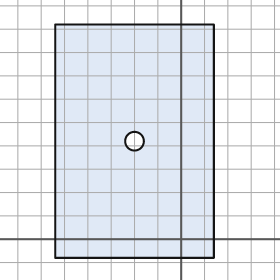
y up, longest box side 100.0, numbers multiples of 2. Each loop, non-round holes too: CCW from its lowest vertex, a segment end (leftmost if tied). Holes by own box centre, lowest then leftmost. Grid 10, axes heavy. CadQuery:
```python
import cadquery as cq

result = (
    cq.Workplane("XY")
    .moveTo(-54.0, -8.0)
    .lineTo(14.0, -8.0)
    .lineTo(14.0, 92.0)
    .lineTo(-54.0, 92.0)
    .close()
    .moveTo(-20.0, 42.0)
    .circle(4.0)
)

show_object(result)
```